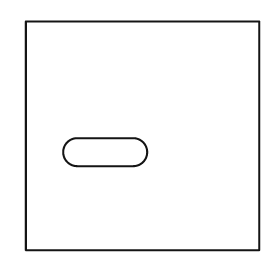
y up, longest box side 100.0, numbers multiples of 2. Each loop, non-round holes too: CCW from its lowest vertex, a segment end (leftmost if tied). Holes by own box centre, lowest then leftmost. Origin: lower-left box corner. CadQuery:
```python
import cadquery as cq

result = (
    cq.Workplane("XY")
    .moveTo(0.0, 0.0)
    .lineTo(100.0, 0.0)
    .lineTo(100.0, 98.0)
    .lineTo(0.0, 98.0)
    .close()
    .moveTo(22.0, 36.0)
    .lineTo(46.0, 36.0)
    .threePointArc((52.0, 42.0), (46.0, 48.0))
    .lineTo(22.0, 48.0)
    .threePointArc((16.0, 42.0), (22.0, 36.0))
    .close()
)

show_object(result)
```